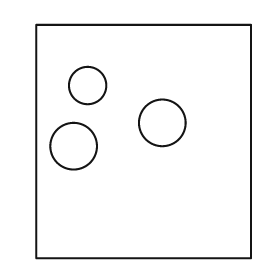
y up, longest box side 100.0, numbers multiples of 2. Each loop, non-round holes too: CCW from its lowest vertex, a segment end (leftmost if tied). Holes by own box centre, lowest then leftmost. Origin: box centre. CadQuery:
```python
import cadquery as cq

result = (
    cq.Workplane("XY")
    .moveTo(-46.0, -50.0)
    .lineTo(46.0, -50.0)
    .lineTo(46.0, 50.0)
    .lineTo(-46.0, 50.0)
    .close()
    .moveTo(-30.0, -2.0)
    .circle(10.0)
    .moveTo(8.0, 8.0)
    .circle(10.0)
    .moveTo(-24.0, 24.0)
    .circle(8.0)
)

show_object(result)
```